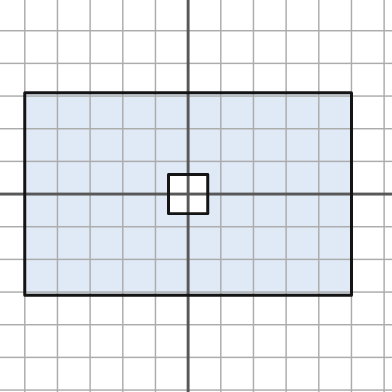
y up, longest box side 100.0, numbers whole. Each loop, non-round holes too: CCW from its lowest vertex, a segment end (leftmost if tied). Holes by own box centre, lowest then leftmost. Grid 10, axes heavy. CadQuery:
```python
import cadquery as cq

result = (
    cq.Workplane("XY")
    .moveTo(-50.0, -31.0)
    .lineTo(50.0, -31.0)
    .lineTo(50.0, 31.0)
    .lineTo(-50.0, 31.0)
    .close()
    .moveTo(-6.0, -6.0)
    .lineTo(6.0, -6.0)
    .lineTo(6.0, 6.0)
    .lineTo(-6.0, 6.0)
    .close()
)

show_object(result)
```